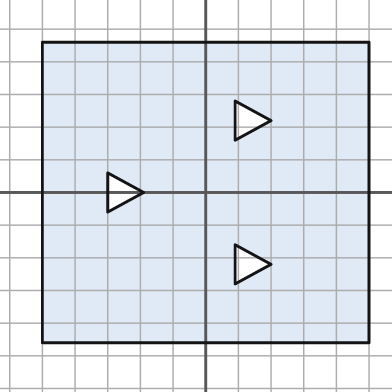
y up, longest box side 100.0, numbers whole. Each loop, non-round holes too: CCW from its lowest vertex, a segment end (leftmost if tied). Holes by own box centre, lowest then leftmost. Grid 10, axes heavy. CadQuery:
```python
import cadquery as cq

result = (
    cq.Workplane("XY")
    .moveTo(-50.0, -46.0)
    .lineTo(50.0, -46.0)
    .lineTo(50.0, 46.0)
    .lineTo(-50.0, 46.0)
    .close()
    .moveTo(9.0, -28.0)
    .lineTo(20.0, -22.0)
    .lineTo(9.0, -16.0)
    .close()
    .moveTo(-30.0, -6.0)
    .lineTo(-19.0, 0.0)
    .lineTo(-30.0, 6.0)
    .close()
    .moveTo(9.0, 16.0)
    .lineTo(20.0, 22.0)
    .lineTo(9.0, 28.0)
    .close()
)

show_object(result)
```